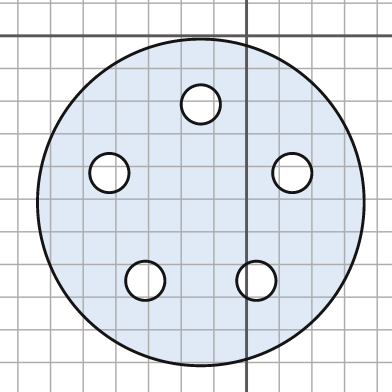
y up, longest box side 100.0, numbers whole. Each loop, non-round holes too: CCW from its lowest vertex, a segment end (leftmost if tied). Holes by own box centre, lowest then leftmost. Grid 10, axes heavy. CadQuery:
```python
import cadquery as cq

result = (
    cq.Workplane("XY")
    .moveTo(-14.0, -51.0)
    .circle(50.0)
    .moveTo(-31.0, -75.0)
    .circle(6.0)
    .moveTo(3.0, -75.0)
    .circle(6.0)
    .moveTo(-42.0, -42.0)
    .circle(6.0)
    .moveTo(14.0, -42.0)
    .circle(6.0)
    .moveTo(-14.0, -21.0)
    .circle(6.0)
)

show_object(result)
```